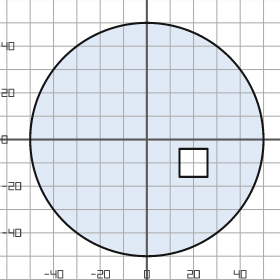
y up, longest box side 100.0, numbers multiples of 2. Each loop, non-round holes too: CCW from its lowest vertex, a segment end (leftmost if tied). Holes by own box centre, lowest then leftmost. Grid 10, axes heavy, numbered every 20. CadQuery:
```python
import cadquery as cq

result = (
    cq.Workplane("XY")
    .moveTo(0.0, 0.0)
    .circle(50.0)
    .moveTo(14.0, -16.0)
    .lineTo(26.0, -16.0)
    .lineTo(26.0, -4.0)
    .lineTo(14.0, -4.0)
    .close()
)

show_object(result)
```